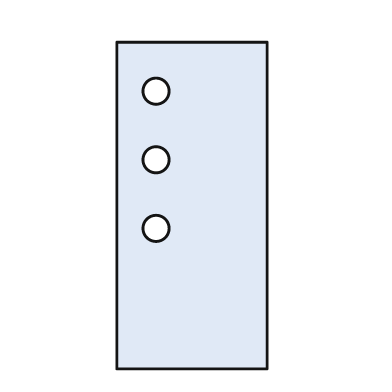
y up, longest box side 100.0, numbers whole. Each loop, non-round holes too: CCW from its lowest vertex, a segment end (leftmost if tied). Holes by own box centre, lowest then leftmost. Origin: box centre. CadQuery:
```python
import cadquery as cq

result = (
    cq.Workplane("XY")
    .moveTo(-23.0, -50.0)
    .lineTo(23.0, -50.0)
    .lineTo(23.0, 50.0)
    .lineTo(-23.0, 50.0)
    .close()
    .moveTo(-11.0, -7.0)
    .circle(4.0)
    .moveTo(-11.0, 14.0)
    .circle(4.0)
    .moveTo(-11.0, 35.0)
    .circle(4.0)
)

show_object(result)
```